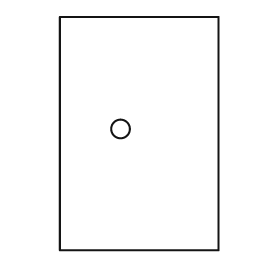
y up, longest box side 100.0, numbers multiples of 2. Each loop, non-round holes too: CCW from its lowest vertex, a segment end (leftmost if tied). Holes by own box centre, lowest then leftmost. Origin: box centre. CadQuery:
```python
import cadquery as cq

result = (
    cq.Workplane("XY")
    .moveTo(-34.0, -50.0)
    .lineTo(34.0, -50.0)
    .lineTo(34.0, 50.0)
    .lineTo(-34.0, 50.0)
    .close()
    .moveTo(-8.0, 2.0)
    .circle(4.0)
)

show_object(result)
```